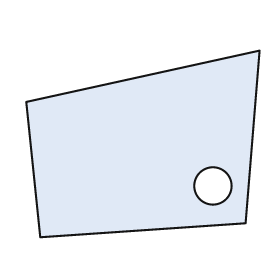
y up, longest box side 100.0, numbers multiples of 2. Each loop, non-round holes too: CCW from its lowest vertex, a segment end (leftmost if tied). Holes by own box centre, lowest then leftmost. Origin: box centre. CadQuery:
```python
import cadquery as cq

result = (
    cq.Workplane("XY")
    .moveTo(-44.0, -40.0)
    .lineTo(44.0, -34.0)
    .lineTo(50.0, 40.0)
    .lineTo(-50.0, 18.0)
    .close()
    .moveTo(30.0, -18.0)
    .circle(8.0)
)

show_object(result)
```